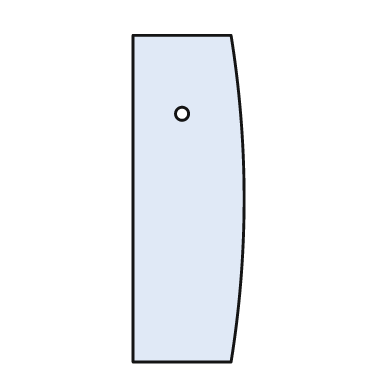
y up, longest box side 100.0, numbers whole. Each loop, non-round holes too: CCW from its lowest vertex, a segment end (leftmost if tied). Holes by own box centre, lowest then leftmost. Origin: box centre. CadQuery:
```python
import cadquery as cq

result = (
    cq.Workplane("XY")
    .moveTo(-17.0, -50.0)
    .lineTo(13.0, -50.0)
    .threePointArc((17.0, 0.0), (13.0, 50.0))
    .lineTo(-17.0, 50.0)
    .close()
    .moveTo(-2.0, 26.0)
    .circle(2.0)
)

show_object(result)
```